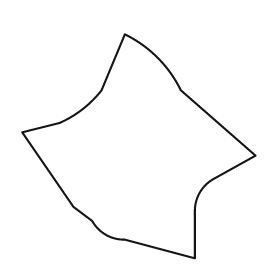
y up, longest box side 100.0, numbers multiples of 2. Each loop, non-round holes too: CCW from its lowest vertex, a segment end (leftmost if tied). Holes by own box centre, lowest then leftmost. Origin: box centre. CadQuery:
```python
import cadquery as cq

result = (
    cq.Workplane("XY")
    .moveTo(24.0, -48.0)
    .lineTo(24.0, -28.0)
    .threePointArc((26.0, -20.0), (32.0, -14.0))
    .lineTo(50.0, -4.0)
    .lineTo(18.0, 24.0)
    .threePointArc((8.0, 38.0), (-6.0, 48.0))
    .lineTo(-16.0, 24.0)
    .threePointArc((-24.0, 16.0), (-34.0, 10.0))
    .lineTo(-50.0, 6.0)
    .lineTo(-28.0, -26.0)
    .lineTo(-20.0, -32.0)
    .threePointArc((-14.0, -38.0), (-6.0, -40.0))
    .close()
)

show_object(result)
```